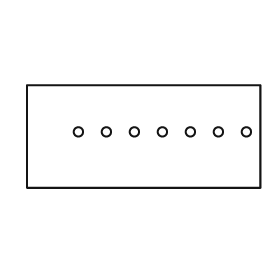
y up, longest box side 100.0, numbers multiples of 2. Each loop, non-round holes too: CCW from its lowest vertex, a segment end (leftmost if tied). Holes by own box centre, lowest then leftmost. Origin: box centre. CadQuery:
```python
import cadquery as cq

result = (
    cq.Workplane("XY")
    .moveTo(-50.0, -22.0)
    .lineTo(50.0, -22.0)
    .lineTo(50.0, 22.0)
    .lineTo(-50.0, 22.0)
    .close()
    .moveTo(-28.0, 2.0)
    .circle(2.0)
    .moveTo(-16.0, 2.0)
    .circle(2.0)
    .moveTo(-4.0, 2.0)
    .circle(2.0)
    .moveTo(8.0, 2.0)
    .circle(2.0)
    .moveTo(20.0, 2.0)
    .circle(2.0)
    .moveTo(32.0, 2.0)
    .circle(2.0)
    .moveTo(44.0, 2.0)
    .circle(2.0)
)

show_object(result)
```